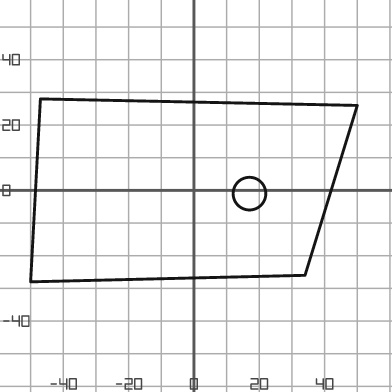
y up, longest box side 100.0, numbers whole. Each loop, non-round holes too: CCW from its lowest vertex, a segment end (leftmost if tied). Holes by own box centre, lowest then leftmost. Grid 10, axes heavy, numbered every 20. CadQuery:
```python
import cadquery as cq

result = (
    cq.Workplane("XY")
    .moveTo(-50.0, -28.0)
    .lineTo(34.0, -26.0)
    .lineTo(50.0, 26.0)
    .lineTo(-47.0, 28.0)
    .close()
    .moveTo(17.0, -1.0)
    .circle(5.0)
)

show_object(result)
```